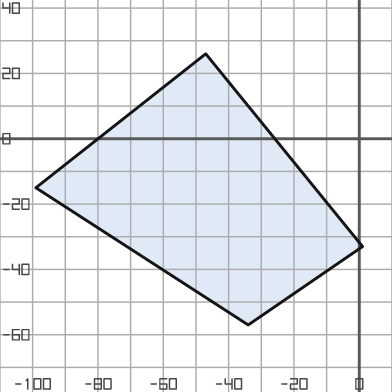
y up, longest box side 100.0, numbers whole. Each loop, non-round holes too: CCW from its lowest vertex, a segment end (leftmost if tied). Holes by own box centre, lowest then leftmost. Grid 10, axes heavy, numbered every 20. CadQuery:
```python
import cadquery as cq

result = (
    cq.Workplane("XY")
    .moveTo(-34.0, -57.0)
    .lineTo(1.0, -33.0)
    .lineTo(-47.0, 26.0)
    .lineTo(-99.0, -15.0)
    .close()
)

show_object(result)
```